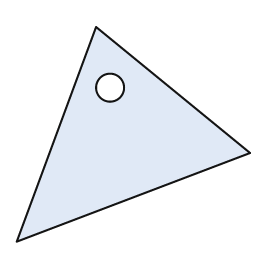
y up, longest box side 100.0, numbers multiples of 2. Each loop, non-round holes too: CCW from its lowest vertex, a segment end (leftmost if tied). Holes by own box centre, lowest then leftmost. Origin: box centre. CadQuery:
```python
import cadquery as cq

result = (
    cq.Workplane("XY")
    .moveTo(-50.0, -46.0)
    .lineTo(50.0, -8.0)
    .lineTo(-16.0, 46.0)
    .close()
    .moveTo(-10.0, 20.0)
    .circle(6.0)
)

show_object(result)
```